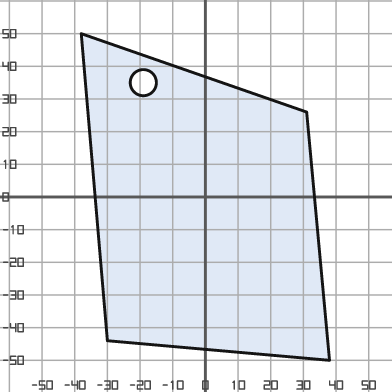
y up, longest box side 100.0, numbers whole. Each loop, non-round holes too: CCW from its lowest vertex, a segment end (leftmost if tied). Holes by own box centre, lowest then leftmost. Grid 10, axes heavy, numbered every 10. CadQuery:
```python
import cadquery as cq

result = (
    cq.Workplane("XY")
    .moveTo(38.0, -50.0)
    .lineTo(31.0, 26.0)
    .lineTo(-38.0, 50.0)
    .lineTo(-30.0, -44.0)
    .close()
    .moveTo(-19.0, 35.0)
    .circle(4.0)
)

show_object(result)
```